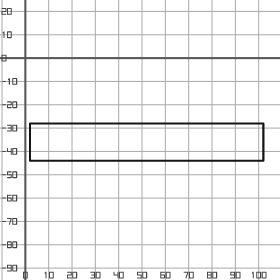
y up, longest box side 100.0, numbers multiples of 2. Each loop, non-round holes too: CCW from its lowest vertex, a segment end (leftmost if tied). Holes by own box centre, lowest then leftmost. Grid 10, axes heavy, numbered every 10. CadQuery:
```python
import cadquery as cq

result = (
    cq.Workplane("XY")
    .moveTo(2.0, -44.0)
    .lineTo(102.0, -44.0)
    .lineTo(102.0, -28.0)
    .lineTo(2.0, -28.0)
    .close()
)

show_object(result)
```